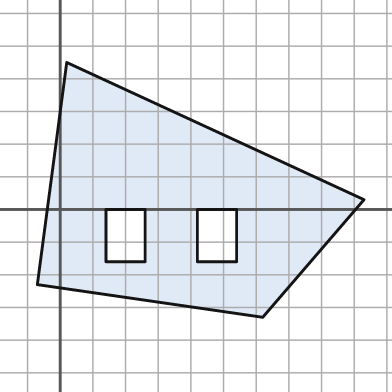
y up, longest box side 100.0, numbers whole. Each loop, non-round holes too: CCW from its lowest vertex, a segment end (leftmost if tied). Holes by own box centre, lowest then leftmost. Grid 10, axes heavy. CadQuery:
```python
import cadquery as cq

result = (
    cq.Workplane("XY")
    .moveTo(62.0, -33.0)
    .lineTo(93.0, 3.0)
    .lineTo(2.0, 45.0)
    .lineTo(-7.0, -23.0)
    .close()
    .moveTo(14.0, -16.0)
    .lineTo(26.0, -16.0)
    .lineTo(26.0, 0.0)
    .lineTo(14.0, 0.0)
    .close()
    .moveTo(42.0, -16.0)
    .lineTo(54.0, -16.0)
    .lineTo(54.0, 0.0)
    .lineTo(42.0, 0.0)
    .close()
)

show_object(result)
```